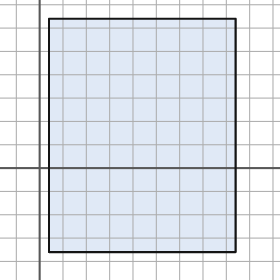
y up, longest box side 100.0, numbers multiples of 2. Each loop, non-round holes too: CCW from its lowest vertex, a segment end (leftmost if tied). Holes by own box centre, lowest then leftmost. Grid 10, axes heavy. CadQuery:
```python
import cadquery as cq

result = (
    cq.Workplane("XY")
    .moveTo(4.0, -36.0)
    .lineTo(84.0, -36.0)
    .lineTo(84.0, 64.0)
    .lineTo(4.0, 64.0)
    .close()
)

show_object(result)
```